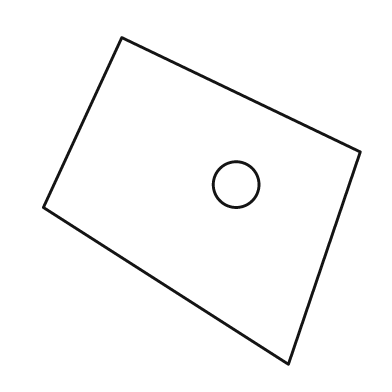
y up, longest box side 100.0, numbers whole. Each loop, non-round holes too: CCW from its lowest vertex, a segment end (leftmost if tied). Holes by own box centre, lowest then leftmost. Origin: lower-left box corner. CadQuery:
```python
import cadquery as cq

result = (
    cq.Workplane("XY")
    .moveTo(75.0, 0.0)
    .lineTo(97.0, 65.0)
    .lineTo(24.0, 100.0)
    .lineTo(0.0, 48.0)
    .close()
    .moveTo(59.0, 55.0)
    .circle(7.0)
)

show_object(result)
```